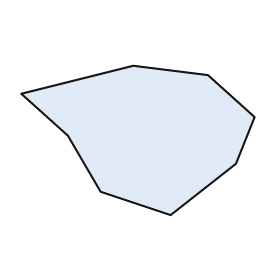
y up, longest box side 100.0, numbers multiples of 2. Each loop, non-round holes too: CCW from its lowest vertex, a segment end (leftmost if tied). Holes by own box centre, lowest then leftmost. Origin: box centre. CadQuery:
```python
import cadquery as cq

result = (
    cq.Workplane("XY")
    .moveTo(14.0, -32.0)
    .lineTo(42.0, -10.0)
    .lineTo(50.0, 10.0)
    .lineTo(30.0, 28.0)
    .lineTo(-2.0, 32.0)
    .lineTo(-50.0, 20.0)
    .lineTo(-30.0, 2.0)
    .lineTo(-16.0, -22.0)
    .close()
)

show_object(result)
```